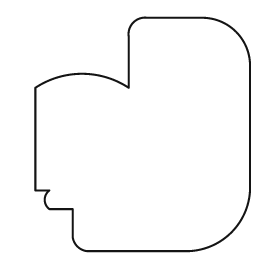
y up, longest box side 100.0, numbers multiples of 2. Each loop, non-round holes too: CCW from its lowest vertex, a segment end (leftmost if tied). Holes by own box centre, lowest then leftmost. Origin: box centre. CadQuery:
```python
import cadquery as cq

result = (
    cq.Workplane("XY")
    .moveTo(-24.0, -50.0)
    .lineTo(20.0, -50.0)
    .threePointArc((38.0, -42.0), (46.0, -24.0))
    .lineTo(46.0, 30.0)
    .threePointArc((40.0, 44.0), (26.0, 50.0))
    .lineTo(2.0, 50.0)
    .threePointArc((-4.0, 48.0), (-6.0, 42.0))
    .lineTo(-6.0, 20.0)
    .threePointArc((-26.0, 26.0), (-46.0, 20.0))
    .lineTo(-46.0, -24.0)
    .lineTo(-40.0, -24.0)
    .threePointArc((-42.0, -28.0), (-40.0, -32.0))
    .lineTo(-30.0, -32.0)
    .lineTo(-30.0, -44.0)
    .threePointArc((-28.0, -48.0), (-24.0, -50.0))
    .close()
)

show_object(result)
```